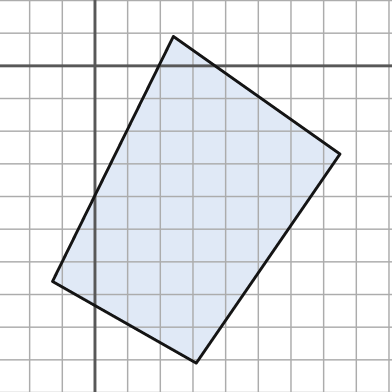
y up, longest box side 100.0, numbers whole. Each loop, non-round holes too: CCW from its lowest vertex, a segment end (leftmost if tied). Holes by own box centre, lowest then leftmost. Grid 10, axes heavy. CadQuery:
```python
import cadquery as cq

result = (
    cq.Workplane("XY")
    .moveTo(31.0, -91.0)
    .lineTo(75.0, -27.0)
    .lineTo(24.0, 9.0)
    .lineTo(-13.0, -66.0)
    .close()
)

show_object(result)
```